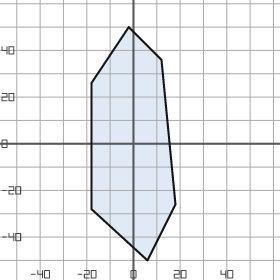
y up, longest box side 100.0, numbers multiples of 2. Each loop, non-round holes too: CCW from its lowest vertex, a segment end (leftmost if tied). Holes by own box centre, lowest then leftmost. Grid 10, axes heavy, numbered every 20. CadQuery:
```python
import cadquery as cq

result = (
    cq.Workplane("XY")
    .moveTo(6.0, -50.0)
    .lineTo(18.0, -26.0)
    .lineTo(12.0, 36.0)
    .lineTo(-2.0, 50.0)
    .lineTo(-18.0, 26.0)
    .lineTo(-18.0, -28.0)
    .close()
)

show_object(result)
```